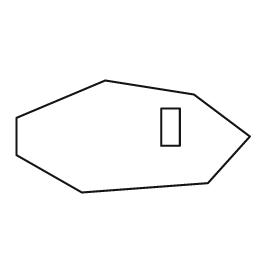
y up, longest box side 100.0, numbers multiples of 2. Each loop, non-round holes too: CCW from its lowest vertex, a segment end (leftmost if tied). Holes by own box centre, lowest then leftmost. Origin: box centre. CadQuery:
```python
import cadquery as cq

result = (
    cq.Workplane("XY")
    .moveTo(-22.0, -24.0)
    .lineTo(32.0, -20.0)
    .lineTo(50.0, 0.0)
    .lineTo(26.0, 18.0)
    .lineTo(-12.0, 24.0)
    .lineTo(-50.0, 8.0)
    .lineTo(-50.0, -8.0)
    .close()
    .moveTo(12.0, -4.0)
    .lineTo(20.0, -4.0)
    .lineTo(20.0, 12.0)
    .lineTo(12.0, 12.0)
    .close()
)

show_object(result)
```